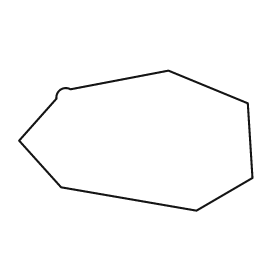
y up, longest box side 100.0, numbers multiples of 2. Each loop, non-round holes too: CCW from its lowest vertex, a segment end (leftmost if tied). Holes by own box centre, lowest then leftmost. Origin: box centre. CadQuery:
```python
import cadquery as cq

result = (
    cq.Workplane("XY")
    .moveTo(26.0, -30.0)
    .lineTo(50.0, -16.0)
    .lineTo(48.0, 16.0)
    .lineTo(14.0, 30.0)
    .lineTo(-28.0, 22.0)
    .threePointArc((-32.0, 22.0), (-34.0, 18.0))
    .lineTo(-50.0, 0.0)
    .lineTo(-32.0, -20.0)
    .close()
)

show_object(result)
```